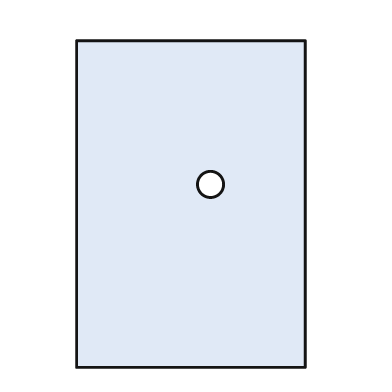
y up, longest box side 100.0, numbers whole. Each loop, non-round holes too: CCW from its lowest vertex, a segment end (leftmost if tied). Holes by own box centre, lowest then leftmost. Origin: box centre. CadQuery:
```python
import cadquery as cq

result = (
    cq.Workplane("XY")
    .moveTo(-35.0, -50.0)
    .lineTo(35.0, -50.0)
    .lineTo(35.0, 50.0)
    .lineTo(-35.0, 50.0)
    .close()
    .moveTo(6.0, 6.0)
    .circle(4.0)
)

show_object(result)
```